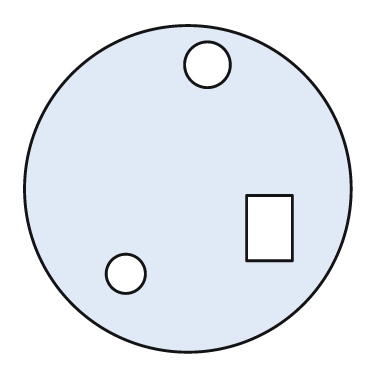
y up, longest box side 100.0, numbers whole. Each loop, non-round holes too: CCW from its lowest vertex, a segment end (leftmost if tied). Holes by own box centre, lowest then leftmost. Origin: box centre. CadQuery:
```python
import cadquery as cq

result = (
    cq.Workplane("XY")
    .moveTo(0.0, 0.0)
    .circle(50.0)
    .moveTo(-19.0, -26.0)
    .circle(6.0)
    .moveTo(18.0, -22.0)
    .lineTo(32.0, -22.0)
    .lineTo(32.0, -2.0)
    .lineTo(18.0, -2.0)
    .close()
    .moveTo(6.0, 38.0)
    .circle(7.0)
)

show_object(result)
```